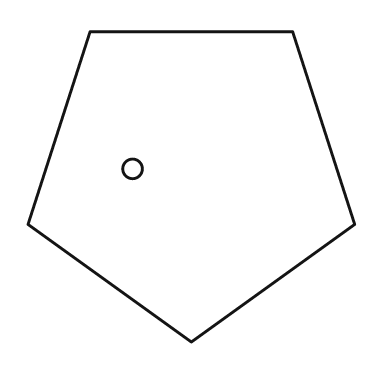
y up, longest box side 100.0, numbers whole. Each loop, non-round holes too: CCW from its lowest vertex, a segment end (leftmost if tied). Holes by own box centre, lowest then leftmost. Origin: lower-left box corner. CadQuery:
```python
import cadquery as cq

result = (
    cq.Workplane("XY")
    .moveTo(50.0, 0.0)
    .lineTo(100.0, 36.0)
    .lineTo(81.0, 95.0)
    .lineTo(19.0, 95.0)
    .lineTo(0.0, 36.0)
    .close()
    .moveTo(32.0, 53.0)
    .circle(3.0)
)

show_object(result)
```